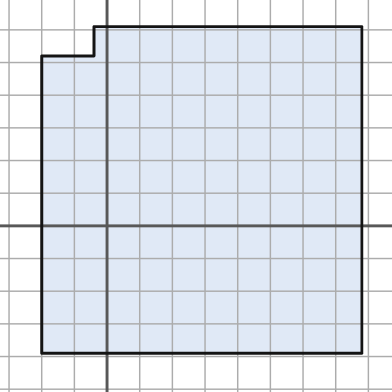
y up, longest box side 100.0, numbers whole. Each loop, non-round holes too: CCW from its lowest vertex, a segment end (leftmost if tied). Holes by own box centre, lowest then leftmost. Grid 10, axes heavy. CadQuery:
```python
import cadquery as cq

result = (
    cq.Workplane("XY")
    .moveTo(-20.0, -39.0)
    .lineTo(78.0, -39.0)
    .lineTo(78.0, 61.0)
    .lineTo(-4.0, 61.0)
    .lineTo(-4.0, 52.0)
    .lineTo(-20.0, 52.0)
    .close()
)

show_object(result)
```